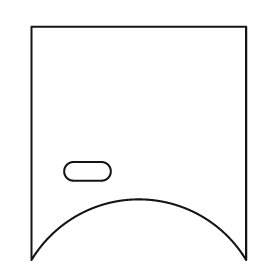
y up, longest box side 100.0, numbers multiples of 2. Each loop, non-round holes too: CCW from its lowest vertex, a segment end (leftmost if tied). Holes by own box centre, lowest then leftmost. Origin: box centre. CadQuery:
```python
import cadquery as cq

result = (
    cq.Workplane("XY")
    .moveTo(-46.0, -50.0)
    .threePointArc((0.0, -24.0), (46.0, -50.0))
    .lineTo(46.0, 50.0)
    .lineTo(-46.0, 50.0)
    .close()
    .moveTo(-28.0, -16.0)
    .lineTo(-16.0, -16.0)
    .threePointArc((-12.0, -12.0), (-16.0, -8.0))
    .lineTo(-28.0, -8.0)
    .threePointArc((-32.0, -12.0), (-28.0, -16.0))
    .close()
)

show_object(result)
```